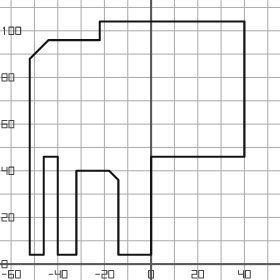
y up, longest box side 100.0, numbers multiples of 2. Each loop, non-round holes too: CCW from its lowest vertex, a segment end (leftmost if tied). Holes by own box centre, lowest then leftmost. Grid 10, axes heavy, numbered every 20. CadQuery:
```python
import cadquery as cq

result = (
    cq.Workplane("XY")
    .moveTo(-52.0, 4.0)
    .lineTo(-46.0, 4.0)
    .lineTo(-46.0, 46.0)
    .lineTo(-40.0, 46.0)
    .lineTo(-40.0, 4.0)
    .lineTo(-32.0, 4.0)
    .lineTo(-32.0, 40.0)
    .lineTo(-18.0, 40.0)
    .lineTo(-14.0, 36.0)
    .lineTo(-14.0, 4.0)
    .lineTo(0.0, 4.0)
    .lineTo(0.0, 46.0)
    .lineTo(40.0, 46.0)
    .lineTo(40.0, 104.0)
    .lineTo(-22.0, 104.0)
    .lineTo(-22.0, 96.0)
    .lineTo(-44.0, 96.0)
    .lineTo(-52.0, 88.0)
    .close()
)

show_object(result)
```